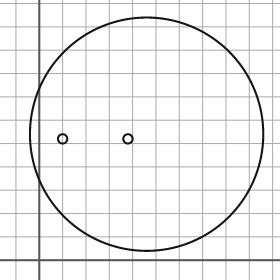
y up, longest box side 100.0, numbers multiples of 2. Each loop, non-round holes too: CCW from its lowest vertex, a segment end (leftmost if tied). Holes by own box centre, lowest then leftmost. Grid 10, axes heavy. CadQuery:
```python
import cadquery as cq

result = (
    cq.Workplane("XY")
    .moveTo(46.0, 54.0)
    .circle(50.0)
    .moveTo(10.0, 52.0)
    .circle(2.0)
    .moveTo(38.0, 52.0)
    .circle(2.0)
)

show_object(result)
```